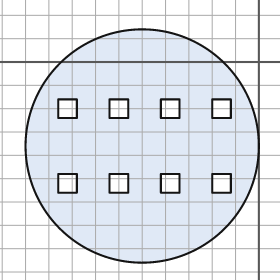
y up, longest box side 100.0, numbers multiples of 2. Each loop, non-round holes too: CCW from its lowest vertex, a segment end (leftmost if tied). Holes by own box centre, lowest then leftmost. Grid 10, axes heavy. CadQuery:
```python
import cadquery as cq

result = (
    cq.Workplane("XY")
    .moveTo(-50.0, -36.0)
    .circle(50.0)
    .moveTo(-86.0, -56.0)
    .lineTo(-78.0, -56.0)
    .lineTo(-78.0, -48.0)
    .lineTo(-86.0, -48.0)
    .close()
    .moveTo(-64.0, -56.0)
    .lineTo(-56.0, -56.0)
    .lineTo(-56.0, -48.0)
    .lineTo(-64.0, -48.0)
    .close()
    .moveTo(-42.0, -56.0)
    .lineTo(-34.0, -56.0)
    .lineTo(-34.0, -48.0)
    .lineTo(-42.0, -48.0)
    .close()
    .moveTo(-20.0, -56.0)
    .lineTo(-12.0, -56.0)
    .lineTo(-12.0, -48.0)
    .lineTo(-20.0, -48.0)
    .close()
    .moveTo(-86.0, -24.0)
    .lineTo(-78.0, -24.0)
    .lineTo(-78.0, -16.0)
    .lineTo(-86.0, -16.0)
    .close()
    .moveTo(-64.0, -24.0)
    .lineTo(-56.0, -24.0)
    .lineTo(-56.0, -16.0)
    .lineTo(-64.0, -16.0)
    .close()
    .moveTo(-42.0, -24.0)
    .lineTo(-34.0, -24.0)
    .lineTo(-34.0, -16.0)
    .lineTo(-42.0, -16.0)
    .close()
    .moveTo(-20.0, -24.0)
    .lineTo(-12.0, -24.0)
    .lineTo(-12.0, -16.0)
    .lineTo(-20.0, -16.0)
    .close()
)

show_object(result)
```